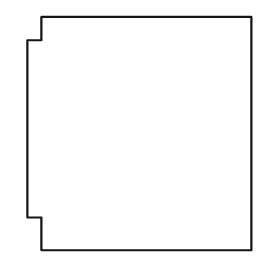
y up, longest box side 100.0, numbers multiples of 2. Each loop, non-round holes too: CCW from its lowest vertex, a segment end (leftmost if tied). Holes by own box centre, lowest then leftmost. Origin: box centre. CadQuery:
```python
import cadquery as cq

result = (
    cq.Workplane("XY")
    .moveTo(-42.0, -50.0)
    .lineTo(48.0, -50.0)
    .lineTo(48.0, 50.0)
    .lineTo(-42.0, 50.0)
    .lineTo(-42.0, 40.0)
    .lineTo(-48.0, 40.0)
    .lineTo(-48.0, -36.0)
    .lineTo(-42.0, -36.0)
    .close()
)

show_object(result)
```